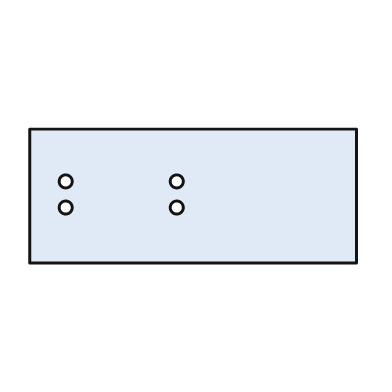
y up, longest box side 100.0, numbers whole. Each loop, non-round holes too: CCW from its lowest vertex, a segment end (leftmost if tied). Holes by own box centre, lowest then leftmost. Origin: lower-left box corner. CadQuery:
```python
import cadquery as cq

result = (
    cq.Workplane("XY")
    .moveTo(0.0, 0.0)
    .lineTo(100.0, 0.0)
    .lineTo(100.0, 41.0)
    .lineTo(0.0, 41.0)
    .close()
    .moveTo(11.0, 17.0)
    .circle(2.0)
    .moveTo(45.0, 17.0)
    .circle(2.0)
    .moveTo(11.0, 25.0)
    .circle(2.0)
    .moveTo(45.0, 25.0)
    .circle(2.0)
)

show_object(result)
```